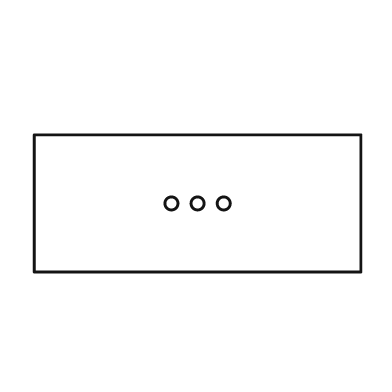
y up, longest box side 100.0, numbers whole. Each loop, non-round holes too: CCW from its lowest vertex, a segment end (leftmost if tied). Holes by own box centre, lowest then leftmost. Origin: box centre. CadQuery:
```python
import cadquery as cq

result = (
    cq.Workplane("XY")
    .moveTo(-50.0, -21.0)
    .lineTo(50.0, -21.0)
    .lineTo(50.0, 21.0)
    .lineTo(-50.0, 21.0)
    .close()
    .moveTo(-8.0, 0.0)
    .circle(2.0)
    .moveTo(0.0, 0.0)
    .circle(2.0)
    .moveTo(8.0, 0.0)
    .circle(2.0)
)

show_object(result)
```